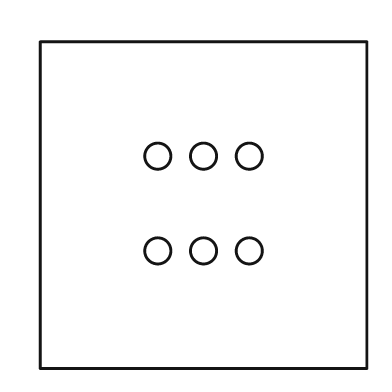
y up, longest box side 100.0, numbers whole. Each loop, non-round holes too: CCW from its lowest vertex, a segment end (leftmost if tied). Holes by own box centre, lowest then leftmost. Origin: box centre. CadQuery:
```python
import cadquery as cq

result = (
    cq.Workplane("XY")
    .moveTo(-50.0, -50.0)
    .lineTo(50.0, -50.0)
    .lineTo(50.0, 50.0)
    .lineTo(-50.0, 50.0)
    .close()
    .moveTo(-14.0, -14.0)
    .circle(4.0)
    .moveTo(0.0, -14.0)
    .circle(4.0)
    .moveTo(14.0, -14.0)
    .circle(4.0)
    .moveTo(-14.0, 15.0)
    .circle(4.0)
    .moveTo(0.0, 15.0)
    .circle(4.0)
    .moveTo(14.0, 15.0)
    .circle(4.0)
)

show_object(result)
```